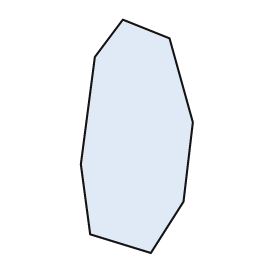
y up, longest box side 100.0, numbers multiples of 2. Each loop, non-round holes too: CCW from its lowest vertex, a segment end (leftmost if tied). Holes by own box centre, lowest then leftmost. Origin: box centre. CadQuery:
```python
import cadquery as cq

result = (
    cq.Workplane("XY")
    .moveTo(6.0, -50.0)
    .lineTo(20.0, -28.0)
    .lineTo(24.0, 6.0)
    .lineTo(14.0, 42.0)
    .lineTo(-6.0, 50.0)
    .lineTo(-18.0, 34.0)
    .lineTo(-24.0, -12.0)
    .lineTo(-20.0, -42.0)
    .close()
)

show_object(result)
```